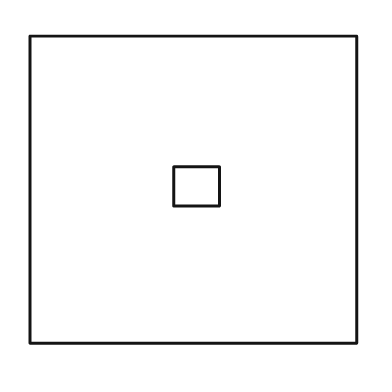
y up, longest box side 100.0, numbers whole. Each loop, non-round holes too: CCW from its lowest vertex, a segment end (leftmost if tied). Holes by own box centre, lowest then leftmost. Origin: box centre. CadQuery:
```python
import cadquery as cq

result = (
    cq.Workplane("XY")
    .moveTo(-50.0, -47.0)
    .lineTo(50.0, -47.0)
    .lineTo(50.0, 47.0)
    .lineTo(-50.0, 47.0)
    .close()
    .moveTo(-6.0, -5.0)
    .lineTo(8.0, -5.0)
    .lineTo(8.0, 7.0)
    .lineTo(-6.0, 7.0)
    .close()
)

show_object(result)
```